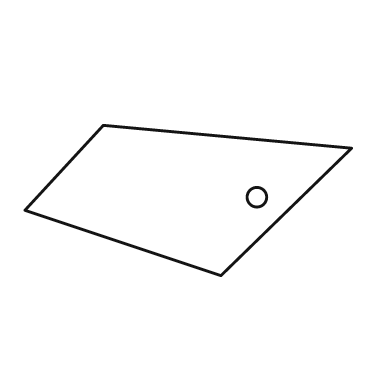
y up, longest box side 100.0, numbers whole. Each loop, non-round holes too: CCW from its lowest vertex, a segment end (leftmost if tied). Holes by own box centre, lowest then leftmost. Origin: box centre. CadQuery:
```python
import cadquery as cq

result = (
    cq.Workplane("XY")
    .moveTo(10.0, -23.0)
    .lineTo(50.0, 16.0)
    .lineTo(-26.0, 23.0)
    .lineTo(-50.0, -3.0)
    .close()
    .moveTo(21.0, 1.0)
    .circle(3.0)
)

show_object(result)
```